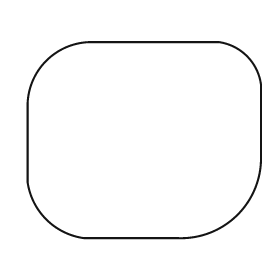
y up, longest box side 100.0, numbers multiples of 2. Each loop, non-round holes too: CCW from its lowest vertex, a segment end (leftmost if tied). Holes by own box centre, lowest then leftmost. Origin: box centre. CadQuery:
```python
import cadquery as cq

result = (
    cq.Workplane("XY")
    .moveTo(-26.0, -42.0)
    .lineTo(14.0, -42.0)
    .threePointArc((40.0, -32.0), (50.0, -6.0))
    .lineTo(50.0, 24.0)
    .threePointArc((44.0, 36.0), (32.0, 42.0))
    .lineTo(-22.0, 42.0)
    .threePointArc((-42.0, 34.0), (-50.0, 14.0))
    .lineTo(-50.0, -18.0)
    .threePointArc((-42.0, -34.0), (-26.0, -42.0))
    .close()
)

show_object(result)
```